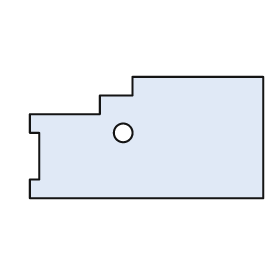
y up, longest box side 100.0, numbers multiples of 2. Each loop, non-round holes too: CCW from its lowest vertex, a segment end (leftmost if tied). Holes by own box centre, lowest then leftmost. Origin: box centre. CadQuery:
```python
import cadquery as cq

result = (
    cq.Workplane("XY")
    .moveTo(-50.0, -26.0)
    .lineTo(50.0, -26.0)
    .lineTo(50.0, 26.0)
    .lineTo(-6.0, 26.0)
    .lineTo(-6.0, 18.0)
    .lineTo(-20.0, 18.0)
    .lineTo(-20.0, 10.0)
    .lineTo(-50.0, 10.0)
    .lineTo(-50.0, 2.0)
    .lineTo(-46.0, 2.0)
    .lineTo(-46.0, -18.0)
    .lineTo(-50.0, -18.0)
    .close()
    .moveTo(-10.0, 2.0)
    .circle(4.0)
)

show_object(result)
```